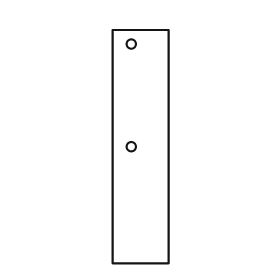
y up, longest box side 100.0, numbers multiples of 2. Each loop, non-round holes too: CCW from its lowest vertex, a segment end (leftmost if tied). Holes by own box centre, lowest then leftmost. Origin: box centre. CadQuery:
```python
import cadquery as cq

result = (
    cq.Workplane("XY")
    .moveTo(-12.0, -50.0)
    .lineTo(12.0, -50.0)
    .lineTo(12.0, 50.0)
    .lineTo(-12.0, 50.0)
    .close()
    .moveTo(-4.0, 0.0)
    .circle(2.0)
    .moveTo(-4.0, 44.0)
    .circle(2.0)
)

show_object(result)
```